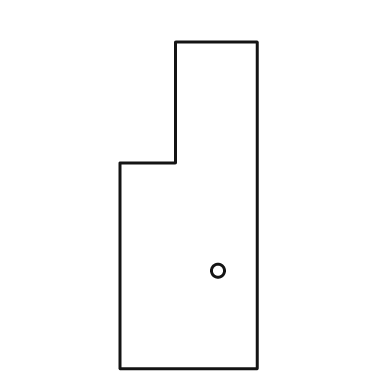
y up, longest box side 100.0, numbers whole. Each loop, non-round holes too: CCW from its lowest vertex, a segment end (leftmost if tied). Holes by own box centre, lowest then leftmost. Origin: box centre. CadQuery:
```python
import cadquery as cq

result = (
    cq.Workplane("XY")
    .moveTo(-21.0, -50.0)
    .lineTo(21.0, -50.0)
    .lineTo(21.0, 50.0)
    .lineTo(-4.0, 50.0)
    .lineTo(-4.0, 13.0)
    .lineTo(-21.0, 13.0)
    .close()
    .moveTo(9.0, -20.0)
    .circle(2.0)
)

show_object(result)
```